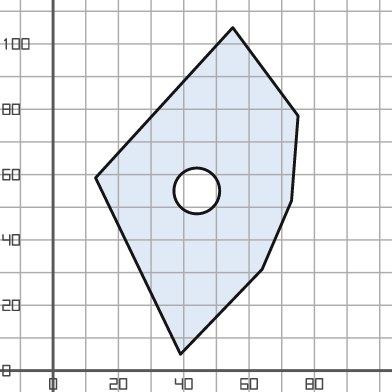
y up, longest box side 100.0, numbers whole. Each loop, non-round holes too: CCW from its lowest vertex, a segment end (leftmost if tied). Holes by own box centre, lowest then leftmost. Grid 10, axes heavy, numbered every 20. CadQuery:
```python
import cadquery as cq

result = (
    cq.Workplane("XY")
    .moveTo(39.0, 5.0)
    .lineTo(64.0, 31.0)
    .lineTo(73.0, 52.0)
    .lineTo(75.0, 78.0)
    .lineTo(55.0, 105.0)
    .lineTo(13.0, 59.0)
    .close()
    .moveTo(44.0, 55.0)
    .circle(7.0)
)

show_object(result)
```